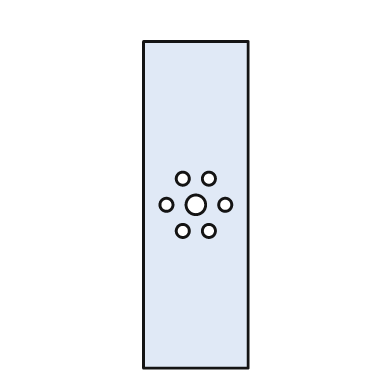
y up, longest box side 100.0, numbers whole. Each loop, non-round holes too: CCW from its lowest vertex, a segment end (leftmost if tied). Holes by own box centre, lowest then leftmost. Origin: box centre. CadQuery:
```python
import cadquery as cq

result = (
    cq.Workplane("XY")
    .moveTo(-16.0, -50.0)
    .lineTo(16.0, -50.0)
    .lineTo(16.0, 50.0)
    .lineTo(-16.0, 50.0)
    .close()
    .moveTo(-4.0, -8.0)
    .circle(2.0)
    .moveTo(4.0, -8.0)
    .circle(2.0)
    .moveTo(-9.0, 0.0)
    .circle(2.0)
    .moveTo(0.0, 0.0)
    .circle(3.0)
    .moveTo(9.0, 0.0)
    .circle(2.0)
    .moveTo(-4.0, 8.0)
    .circle(2.0)
    .moveTo(4.0, 8.0)
    .circle(2.0)
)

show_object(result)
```